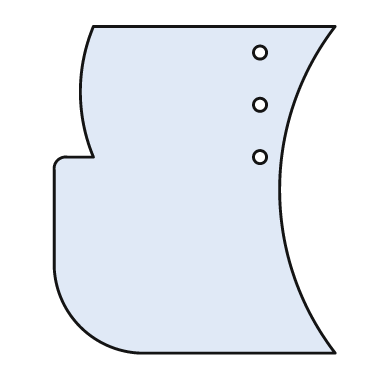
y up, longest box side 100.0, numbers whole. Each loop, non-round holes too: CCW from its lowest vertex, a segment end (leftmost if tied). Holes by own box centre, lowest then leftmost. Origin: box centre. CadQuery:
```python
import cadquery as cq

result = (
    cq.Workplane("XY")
    .moveTo(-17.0, -50.0)
    .lineTo(43.0, -50.0)
    .threePointArc((26.0, 0.0), (43.0, 50.0))
    .lineTo(-31.0, 50.0)
    .threePointArc((-35.0, 30.0), (-31.0, 10.0))
    .lineTo(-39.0, 10.0)
    .threePointArc((-42.0, 9.0), (-43.0, 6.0))
    .lineTo(-43.0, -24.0)
    .threePointArc((-35.0, -42.0), (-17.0, -50.0))
    .close()
    .moveTo(20.0, 10.0)
    .circle(2.0)
    .moveTo(20.0, 26.0)
    .circle(2.0)
    .moveTo(20.0, 42.0)
    .circle(2.0)
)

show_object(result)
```